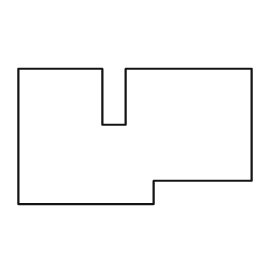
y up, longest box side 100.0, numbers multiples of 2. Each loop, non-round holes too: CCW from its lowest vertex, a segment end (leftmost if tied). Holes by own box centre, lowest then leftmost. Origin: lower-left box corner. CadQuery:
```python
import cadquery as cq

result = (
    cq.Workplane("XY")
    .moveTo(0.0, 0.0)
    .lineTo(58.0, 0.0)
    .lineTo(58.0, 10.0)
    .lineTo(100.0, 10.0)
    .lineTo(100.0, 58.0)
    .lineTo(46.0, 58.0)
    .lineTo(46.0, 34.0)
    .lineTo(36.0, 34.0)
    .lineTo(36.0, 58.0)
    .lineTo(0.0, 58.0)
    .close()
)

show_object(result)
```